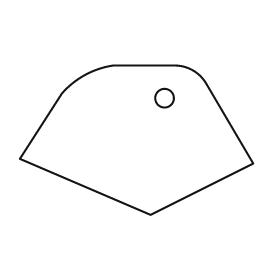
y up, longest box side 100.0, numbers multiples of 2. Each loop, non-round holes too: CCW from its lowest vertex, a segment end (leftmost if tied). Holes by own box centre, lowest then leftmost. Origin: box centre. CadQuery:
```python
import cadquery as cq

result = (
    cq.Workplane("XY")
    .moveTo(6.0, -32.0)
    .lineTo(50.0, -10.0)
    .lineTo(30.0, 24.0)
    .threePointArc((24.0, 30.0), (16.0, 32.0))
    .lineTo(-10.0, 32.0)
    .threePointArc((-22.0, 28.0), (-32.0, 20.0))
    .lineTo(-50.0, -8.0)
    .close()
    .moveTo(12.0, 18.0)
    .circle(4.0)
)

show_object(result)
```